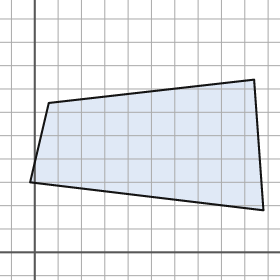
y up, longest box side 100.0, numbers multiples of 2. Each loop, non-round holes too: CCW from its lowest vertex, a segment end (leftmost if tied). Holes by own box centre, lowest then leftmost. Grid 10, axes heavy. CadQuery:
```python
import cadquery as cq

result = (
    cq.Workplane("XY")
    .moveTo(98.0, 18.0)
    .lineTo(94.0, 74.0)
    .lineTo(6.0, 64.0)
    .lineTo(-2.0, 30.0)
    .close()
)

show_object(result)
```